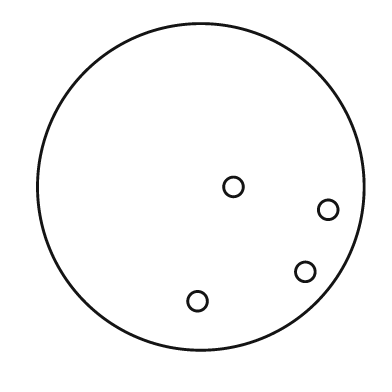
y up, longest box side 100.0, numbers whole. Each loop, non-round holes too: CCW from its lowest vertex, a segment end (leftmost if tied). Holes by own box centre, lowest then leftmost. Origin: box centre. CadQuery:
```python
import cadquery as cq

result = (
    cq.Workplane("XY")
    .moveTo(0.0, 0.0)
    .circle(50.0)
    .moveTo(-1.0, -35.0)
    .circle(3.0)
    .moveTo(32.0, -26.0)
    .circle(3.0)
    .moveTo(39.0, -7.0)
    .circle(3.0)
    .moveTo(10.0, 0.0)
    .circle(3.0)
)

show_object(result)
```